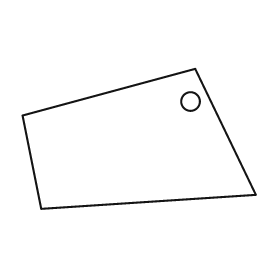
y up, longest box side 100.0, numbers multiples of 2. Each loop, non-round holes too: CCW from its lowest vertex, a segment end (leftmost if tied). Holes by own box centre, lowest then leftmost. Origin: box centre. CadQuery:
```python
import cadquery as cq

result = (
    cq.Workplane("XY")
    .moveTo(-42.0, -30.0)
    .lineTo(50.0, -24.0)
    .lineTo(24.0, 30.0)
    .lineTo(-50.0, 10.0)
    .close()
    .moveTo(22.0, 16.0)
    .circle(4.0)
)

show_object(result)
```